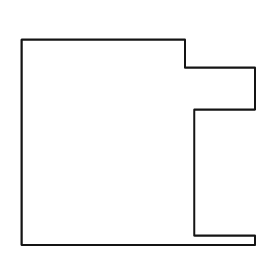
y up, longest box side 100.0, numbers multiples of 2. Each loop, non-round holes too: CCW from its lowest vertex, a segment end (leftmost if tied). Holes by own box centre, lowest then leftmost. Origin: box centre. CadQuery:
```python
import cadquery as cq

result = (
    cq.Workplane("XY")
    .moveTo(-50.0, -44.0)
    .lineTo(50.0, -44.0)
    .lineTo(50.0, -40.0)
    .lineTo(24.0, -40.0)
    .lineTo(24.0, 14.0)
    .lineTo(50.0, 14.0)
    .lineTo(50.0, 32.0)
    .lineTo(20.0, 32.0)
    .lineTo(20.0, 44.0)
    .lineTo(-50.0, 44.0)
    .close()
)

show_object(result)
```